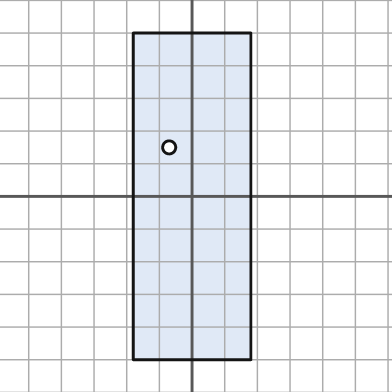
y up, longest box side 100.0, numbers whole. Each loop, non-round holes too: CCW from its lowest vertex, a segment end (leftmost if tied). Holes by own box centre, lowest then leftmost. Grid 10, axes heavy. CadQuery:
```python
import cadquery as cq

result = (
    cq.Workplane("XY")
    .moveTo(-18.0, -50.0)
    .lineTo(18.0, -50.0)
    .lineTo(18.0, 50.0)
    .lineTo(-18.0, 50.0)
    .close()
    .moveTo(-7.0, 15.0)
    .circle(2.0)
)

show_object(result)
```